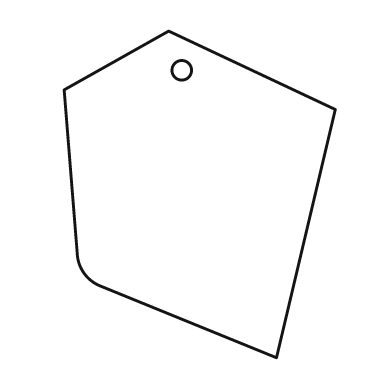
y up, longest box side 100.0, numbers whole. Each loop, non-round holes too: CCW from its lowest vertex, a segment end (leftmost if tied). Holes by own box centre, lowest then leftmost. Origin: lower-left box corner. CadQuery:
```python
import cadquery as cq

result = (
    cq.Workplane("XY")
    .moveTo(65.0, 0.0)
    .lineTo(83.0, 76.0)
    .lineTo(32.0, 100.0)
    .lineTo(0.0, 82.0)
    .lineTo(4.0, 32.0)
    .threePointArc((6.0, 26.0), (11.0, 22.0))
    .close()
    .moveTo(36.0, 88.0)
    .circle(3.0)
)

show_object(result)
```